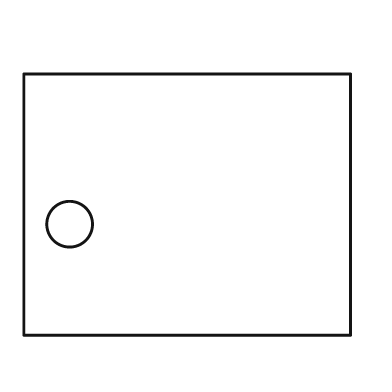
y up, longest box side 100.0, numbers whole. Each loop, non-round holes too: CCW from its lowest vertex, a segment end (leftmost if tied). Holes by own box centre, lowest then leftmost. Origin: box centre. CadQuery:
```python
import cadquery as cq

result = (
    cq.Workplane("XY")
    .moveTo(-50.0, -40.0)
    .lineTo(50.0, -40.0)
    .lineTo(50.0, 40.0)
    .lineTo(-50.0, 40.0)
    .close()
    .moveTo(-36.0, -6.0)
    .circle(7.0)
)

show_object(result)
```